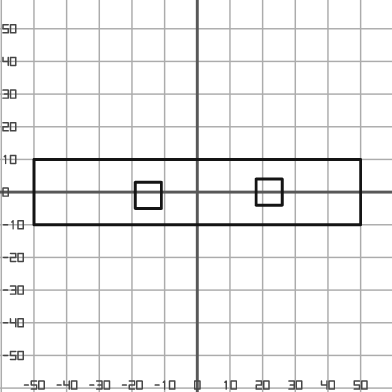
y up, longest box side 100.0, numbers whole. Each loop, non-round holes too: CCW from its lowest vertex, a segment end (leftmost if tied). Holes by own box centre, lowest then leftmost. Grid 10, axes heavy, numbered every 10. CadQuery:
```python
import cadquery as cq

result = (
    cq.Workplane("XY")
    .moveTo(-50.0, -10.0)
    .lineTo(50.0, -10.0)
    .lineTo(50.0, 10.0)
    .lineTo(-50.0, 10.0)
    .close()
    .moveTo(-19.0, -5.0)
    .lineTo(-11.0, -5.0)
    .lineTo(-11.0, 3.0)
    .lineTo(-19.0, 3.0)
    .close()
    .moveTo(18.0, -4.0)
    .lineTo(26.0, -4.0)
    .lineTo(26.0, 4.0)
    .lineTo(18.0, 4.0)
    .close()
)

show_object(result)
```